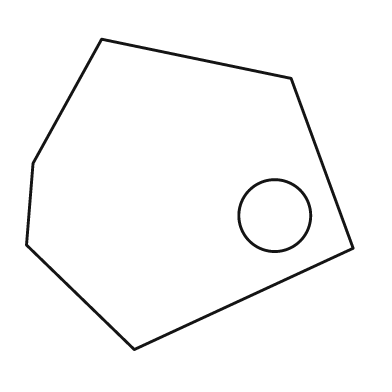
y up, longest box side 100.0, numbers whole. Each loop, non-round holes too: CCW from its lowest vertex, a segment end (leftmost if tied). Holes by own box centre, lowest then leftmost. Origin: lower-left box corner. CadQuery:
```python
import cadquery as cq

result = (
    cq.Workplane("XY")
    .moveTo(33.0, 0.0)
    .lineTo(100.0, 31.0)
    .lineTo(81.0, 83.0)
    .lineTo(23.0, 95.0)
    .lineTo(2.0, 57.0)
    .lineTo(0.0, 32.0)
    .close()
    .moveTo(76.0, 41.0)
    .circle(11.0)
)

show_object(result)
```